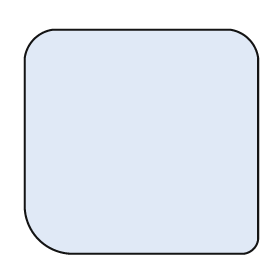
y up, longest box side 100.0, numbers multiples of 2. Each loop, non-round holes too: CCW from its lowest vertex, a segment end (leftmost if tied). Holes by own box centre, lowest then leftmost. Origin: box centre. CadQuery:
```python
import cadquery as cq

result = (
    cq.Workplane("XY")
    .moveTo(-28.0, -48.0)
    .lineTo(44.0, -48.0)
    .threePointArc((48.0, -46.0), (50.0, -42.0))
    .lineTo(50.0, 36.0)
    .threePointArc((46.0, 44.0), (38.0, 48.0))
    .lineTo(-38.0, 48.0)
    .threePointArc((-46.0, 44.0), (-50.0, 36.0))
    .lineTo(-50.0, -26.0)
    .threePointArc((-44.0, -42.0), (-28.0, -48.0))
    .close()
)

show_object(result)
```